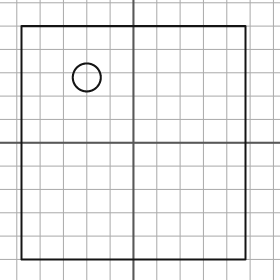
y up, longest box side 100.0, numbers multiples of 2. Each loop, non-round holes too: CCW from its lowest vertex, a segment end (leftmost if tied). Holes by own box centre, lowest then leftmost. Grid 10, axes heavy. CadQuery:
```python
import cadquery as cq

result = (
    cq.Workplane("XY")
    .moveTo(-48.0, -50.0)
    .lineTo(48.0, -50.0)
    .lineTo(48.0, 50.0)
    .lineTo(-48.0, 50.0)
    .close()
    .moveTo(-20.0, 28.0)
    .circle(6.0)
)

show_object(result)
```